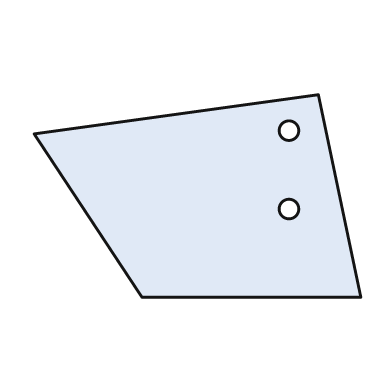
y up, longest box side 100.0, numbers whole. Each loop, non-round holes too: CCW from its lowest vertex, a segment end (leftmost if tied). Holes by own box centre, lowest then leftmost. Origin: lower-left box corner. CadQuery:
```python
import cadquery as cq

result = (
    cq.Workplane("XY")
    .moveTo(33.0, 0.0)
    .lineTo(100.0, 0.0)
    .lineTo(87.0, 62.0)
    .lineTo(0.0, 50.0)
    .close()
    .moveTo(78.0, 27.0)
    .circle(3.0)
    .moveTo(78.0, 51.0)
    .circle(3.0)
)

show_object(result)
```